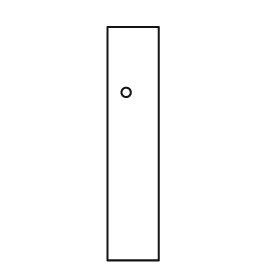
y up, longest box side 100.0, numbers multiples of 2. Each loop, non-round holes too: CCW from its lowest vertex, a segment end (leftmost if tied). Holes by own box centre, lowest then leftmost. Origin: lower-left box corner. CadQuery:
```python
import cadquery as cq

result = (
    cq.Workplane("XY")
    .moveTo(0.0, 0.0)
    .lineTo(22.0, 0.0)
    .lineTo(22.0, 100.0)
    .lineTo(0.0, 100.0)
    .close()
    .moveTo(8.0, 72.0)
    .circle(2.0)
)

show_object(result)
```